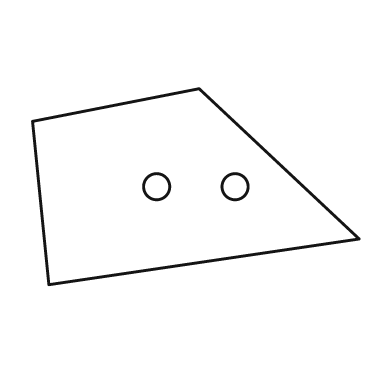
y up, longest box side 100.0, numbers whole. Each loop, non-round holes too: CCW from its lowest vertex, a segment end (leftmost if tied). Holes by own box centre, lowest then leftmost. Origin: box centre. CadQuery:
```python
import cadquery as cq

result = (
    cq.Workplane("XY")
    .moveTo(-45.0, -30.0)
    .lineTo(50.0, -16.0)
    .lineTo(1.0, 30.0)
    .lineTo(-50.0, 20.0)
    .close()
    .moveTo(-12.0, 0.0)
    .circle(4.0)
    .moveTo(12.0, 0.0)
    .circle(4.0)
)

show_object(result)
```